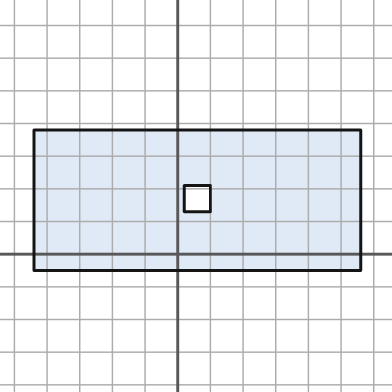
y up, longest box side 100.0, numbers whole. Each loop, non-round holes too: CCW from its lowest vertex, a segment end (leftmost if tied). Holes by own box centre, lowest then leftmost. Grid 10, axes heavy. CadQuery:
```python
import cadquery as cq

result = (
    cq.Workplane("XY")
    .moveTo(-44.0, -5.0)
    .lineTo(56.0, -5.0)
    .lineTo(56.0, 38.0)
    .lineTo(-44.0, 38.0)
    .close()
    .moveTo(2.0, 13.0)
    .lineTo(10.0, 13.0)
    .lineTo(10.0, 21.0)
    .lineTo(2.0, 21.0)
    .close()
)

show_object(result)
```